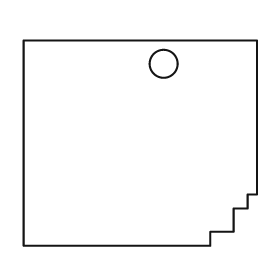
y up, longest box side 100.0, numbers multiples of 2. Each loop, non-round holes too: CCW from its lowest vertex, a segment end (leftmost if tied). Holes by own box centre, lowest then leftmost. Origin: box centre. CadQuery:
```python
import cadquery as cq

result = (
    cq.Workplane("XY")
    .moveTo(-50.0, -44.0)
    .lineTo(30.0, -44.0)
    .lineTo(30.0, -38.0)
    .lineTo(40.0, -38.0)
    .lineTo(40.0, -28.0)
    .lineTo(46.0, -28.0)
    .lineTo(46.0, -22.0)
    .lineTo(50.0, -22.0)
    .lineTo(50.0, 44.0)
    .lineTo(-50.0, 44.0)
    .close()
    .moveTo(10.0, 34.0)
    .circle(6.0)
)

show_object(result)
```